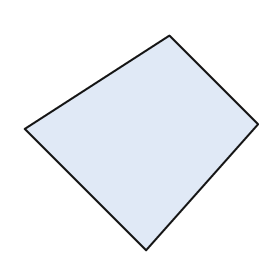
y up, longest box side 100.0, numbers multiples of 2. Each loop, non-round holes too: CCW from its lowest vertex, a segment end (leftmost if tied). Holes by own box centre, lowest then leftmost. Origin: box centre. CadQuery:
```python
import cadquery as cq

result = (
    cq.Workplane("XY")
    .moveTo(2.0, -46.0)
    .lineTo(50.0, 8.0)
    .lineTo(12.0, 46.0)
    .lineTo(-50.0, 6.0)
    .close()
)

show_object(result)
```